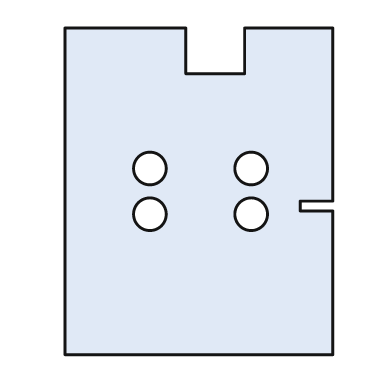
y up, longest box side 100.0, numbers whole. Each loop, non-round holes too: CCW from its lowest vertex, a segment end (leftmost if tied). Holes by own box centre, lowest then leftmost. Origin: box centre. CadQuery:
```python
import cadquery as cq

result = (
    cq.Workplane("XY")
    .moveTo(-41.0, -50.0)
    .lineTo(41.0, -50.0)
    .lineTo(41.0, -6.0)
    .lineTo(31.0, -6.0)
    .lineTo(31.0, -3.0)
    .lineTo(41.0, -3.0)
    .lineTo(41.0, 50.0)
    .lineTo(14.0, 50.0)
    .lineTo(14.0, 36.0)
    .lineTo(-4.0, 36.0)
    .lineTo(-4.0, 50.0)
    .lineTo(-41.0, 50.0)
    .close()
    .moveTo(-15.0, -7.0)
    .circle(5.0)
    .moveTo(16.0, -7.0)
    .circle(5.0)
    .moveTo(-15.0, 7.0)
    .circle(5.0)
    .moveTo(16.0, 7.0)
    .circle(5.0)
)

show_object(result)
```